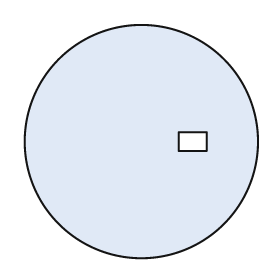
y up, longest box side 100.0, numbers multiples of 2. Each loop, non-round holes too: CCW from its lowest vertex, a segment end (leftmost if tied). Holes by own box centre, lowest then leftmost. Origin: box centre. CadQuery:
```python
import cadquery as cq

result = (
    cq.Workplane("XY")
    .moveTo(0.0, 0.0)
    .circle(50.0)
    .moveTo(16.0, -4.0)
    .lineTo(28.0, -4.0)
    .lineTo(28.0, 4.0)
    .lineTo(16.0, 4.0)
    .close()
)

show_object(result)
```